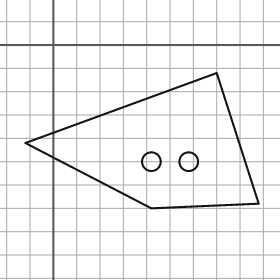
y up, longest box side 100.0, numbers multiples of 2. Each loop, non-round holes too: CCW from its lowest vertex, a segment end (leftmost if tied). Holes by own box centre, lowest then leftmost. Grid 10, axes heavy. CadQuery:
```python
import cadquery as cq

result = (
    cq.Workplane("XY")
    .moveTo(42.0, -70.0)
    .lineTo(88.0, -68.0)
    .lineTo(70.0, -12.0)
    .lineTo(-12.0, -42.0)
    .close()
    .moveTo(42.0, -50.0)
    .circle(4.0)
    .moveTo(58.0, -50.0)
    .circle(4.0)
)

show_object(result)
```